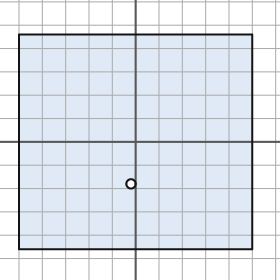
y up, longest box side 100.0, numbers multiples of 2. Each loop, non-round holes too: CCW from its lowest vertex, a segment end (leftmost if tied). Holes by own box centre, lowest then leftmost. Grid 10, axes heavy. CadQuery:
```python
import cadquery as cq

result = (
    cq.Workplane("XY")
    .moveTo(-50.0, -46.0)
    .lineTo(50.0, -46.0)
    .lineTo(50.0, 46.0)
    .lineTo(-50.0, 46.0)
    .close()
    .moveTo(-2.0, -18.0)
    .circle(2.0)
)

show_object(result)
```